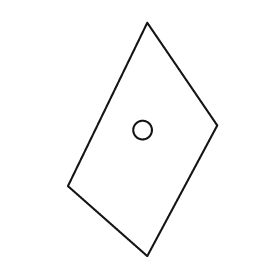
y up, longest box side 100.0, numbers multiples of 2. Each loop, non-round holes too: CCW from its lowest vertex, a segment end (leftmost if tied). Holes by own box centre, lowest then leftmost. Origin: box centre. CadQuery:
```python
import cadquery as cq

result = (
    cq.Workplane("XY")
    .moveTo(2.0, -50.0)
    .lineTo(32.0, 6.0)
    .lineTo(2.0, 50.0)
    .lineTo(-32.0, -20.0)
    .close()
    .moveTo(0.0, 4.0)
    .circle(4.0)
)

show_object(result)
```